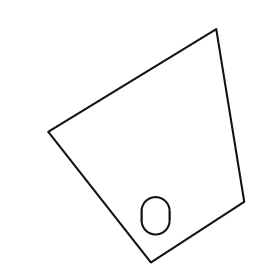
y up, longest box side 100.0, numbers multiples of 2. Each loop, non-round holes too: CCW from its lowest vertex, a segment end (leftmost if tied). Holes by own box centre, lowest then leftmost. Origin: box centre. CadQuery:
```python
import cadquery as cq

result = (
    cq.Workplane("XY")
    .moveTo(2.0, -50.0)
    .lineTo(42.0, -24.0)
    .lineTo(30.0, 50.0)
    .lineTo(-42.0, 6.0)
    .close()
    .moveTo(-2.0, -32.0)
    .threePointArc((4.0, -38.0), (10.0, -32.0))
    .lineTo(10.0, -28.0)
    .threePointArc((4.0, -22.0), (-2.0, -28.0))
    .close()
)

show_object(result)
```